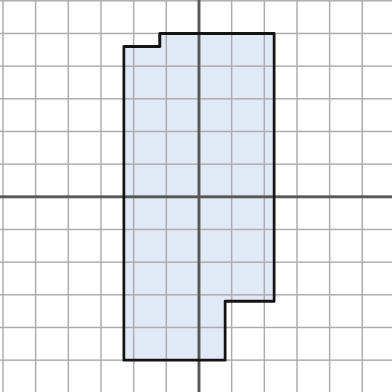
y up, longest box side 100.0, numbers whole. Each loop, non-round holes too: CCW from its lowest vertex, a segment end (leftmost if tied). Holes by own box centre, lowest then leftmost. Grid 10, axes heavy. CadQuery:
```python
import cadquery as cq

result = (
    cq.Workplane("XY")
    .moveTo(-23.0, -50.0)
    .lineTo(8.0, -50.0)
    .lineTo(8.0, -32.0)
    .lineTo(23.0, -32.0)
    .lineTo(23.0, 50.0)
    .lineTo(-12.0, 50.0)
    .lineTo(-12.0, 46.0)
    .lineTo(-23.0, 46.0)
    .close()
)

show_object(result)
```